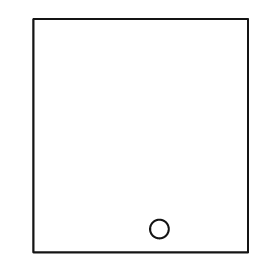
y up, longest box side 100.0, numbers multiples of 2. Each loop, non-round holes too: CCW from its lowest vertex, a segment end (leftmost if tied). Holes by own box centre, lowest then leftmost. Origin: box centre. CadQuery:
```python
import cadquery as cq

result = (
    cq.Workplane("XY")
    .moveTo(-46.0, -50.0)
    .lineTo(46.0, -50.0)
    .lineTo(46.0, 50.0)
    .lineTo(-46.0, 50.0)
    .close()
    .moveTo(8.0, -40.0)
    .circle(4.0)
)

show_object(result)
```